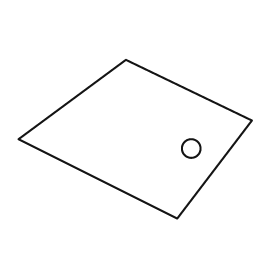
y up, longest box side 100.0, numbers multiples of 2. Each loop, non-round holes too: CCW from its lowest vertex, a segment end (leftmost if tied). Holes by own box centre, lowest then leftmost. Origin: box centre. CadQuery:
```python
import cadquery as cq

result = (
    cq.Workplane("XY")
    .moveTo(18.0, -34.0)
    .lineTo(50.0, 8.0)
    .lineTo(-4.0, 34.0)
    .lineTo(-50.0, 0.0)
    .close()
    .moveTo(24.0, -4.0)
    .circle(4.0)
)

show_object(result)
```